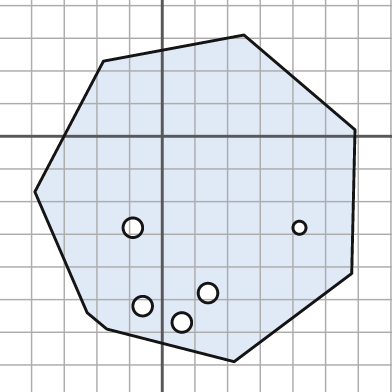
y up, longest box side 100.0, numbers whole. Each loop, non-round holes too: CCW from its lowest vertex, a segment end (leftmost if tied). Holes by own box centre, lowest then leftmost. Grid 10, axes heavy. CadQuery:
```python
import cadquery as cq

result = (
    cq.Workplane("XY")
    .moveTo(22.0, -69.0)
    .lineTo(58.0, -42.0)
    .lineTo(59.0, 2.0)
    .lineTo(25.0, 31.0)
    .lineTo(-18.0, 23.0)
    .lineTo(-39.0, -17.0)
    .lineTo(-23.0, -54.0)
    .lineTo(-17.0, -59.0)
    .close()
    .moveTo(6.0, -57.0)
    .circle(3.0)
    .moveTo(-6.0, -52.0)
    .circle(3.0)
    .moveTo(14.0, -48.0)
    .circle(3.0)
    .moveTo(-9.0, -28.0)
    .circle(3.0)
    .moveTo(42.0, -28.0)
    .circle(2.0)
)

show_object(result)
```